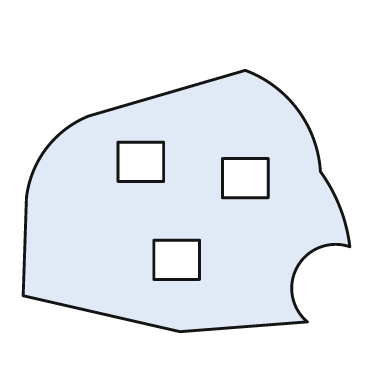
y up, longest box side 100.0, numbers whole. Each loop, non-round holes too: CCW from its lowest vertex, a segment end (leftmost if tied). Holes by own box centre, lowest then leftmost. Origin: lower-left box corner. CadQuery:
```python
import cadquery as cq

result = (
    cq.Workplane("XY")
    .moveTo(48.0, 0.0)
    .lineTo(87.0, 3.0)
    .threePointArc((84.0, 20.0), (100.0, 26.0))
    .threePointArc((97.0, 38.0), (91.0, 49.0))
    .threePointArc((84.0, 68.0), (68.0, 80.0))
    .lineTo(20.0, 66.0)
    .threePointArc((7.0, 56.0), (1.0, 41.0))
    .lineTo(0.0, 11.0)
    .close()
    .moveTo(40.0, 16.0)
    .lineTo(54.0, 16.0)
    .lineTo(54.0, 28.0)
    .lineTo(40.0, 28.0)
    .close()
    .moveTo(61.0, 41.0)
    .lineTo(75.0, 41.0)
    .lineTo(75.0, 53.0)
    .lineTo(61.0, 53.0)
    .close()
    .moveTo(29.0, 46.0)
    .lineTo(43.0, 46.0)
    .lineTo(43.0, 58.0)
    .lineTo(29.0, 58.0)
    .close()
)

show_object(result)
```